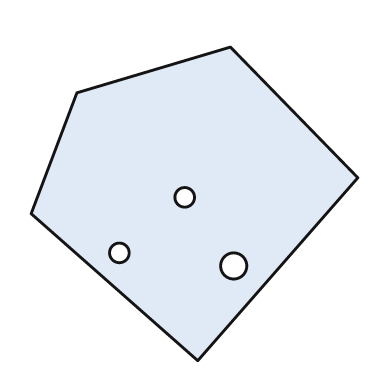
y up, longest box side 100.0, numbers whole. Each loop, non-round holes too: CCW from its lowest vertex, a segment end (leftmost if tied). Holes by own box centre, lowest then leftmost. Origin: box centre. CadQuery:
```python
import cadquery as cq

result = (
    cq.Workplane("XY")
    .moveTo(1.0, -48.0)
    .lineTo(50.0, 8.0)
    .lineTo(11.0, 48.0)
    .lineTo(-36.0, 34.0)
    .lineTo(-50.0, -3.0)
    .close()
    .moveTo(12.0, -19.0)
    .circle(4.0)
    .moveTo(-23.0, -15.0)
    .circle(3.0)
    .moveTo(-3.0, 2.0)
    .circle(3.0)
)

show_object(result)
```